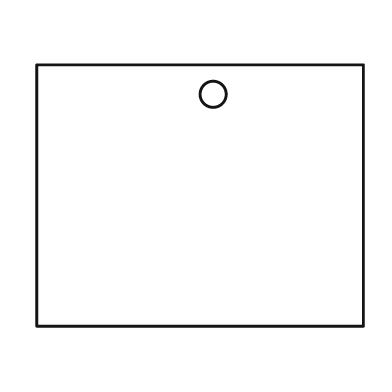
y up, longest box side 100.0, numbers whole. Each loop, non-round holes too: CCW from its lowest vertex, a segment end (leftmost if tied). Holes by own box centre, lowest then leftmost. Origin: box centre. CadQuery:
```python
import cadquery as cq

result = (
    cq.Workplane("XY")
    .moveTo(-50.0, -40.0)
    .lineTo(50.0, -40.0)
    .lineTo(50.0, 40.0)
    .lineTo(-50.0, 40.0)
    .close()
    .moveTo(4.0, 31.0)
    .circle(4.0)
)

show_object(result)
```